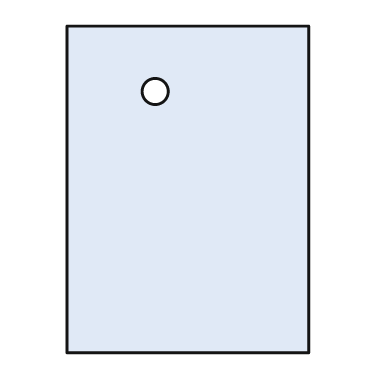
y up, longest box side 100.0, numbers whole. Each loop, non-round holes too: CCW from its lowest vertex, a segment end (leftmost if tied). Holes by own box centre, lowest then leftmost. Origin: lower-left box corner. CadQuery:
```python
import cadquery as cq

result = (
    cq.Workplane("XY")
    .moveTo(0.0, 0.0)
    .lineTo(74.0, 0.0)
    .lineTo(74.0, 100.0)
    .lineTo(0.0, 100.0)
    .close()
    .moveTo(27.0, 80.0)
    .circle(4.0)
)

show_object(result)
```